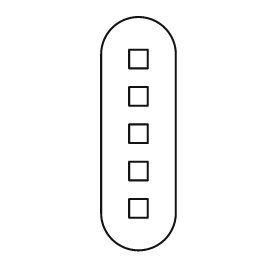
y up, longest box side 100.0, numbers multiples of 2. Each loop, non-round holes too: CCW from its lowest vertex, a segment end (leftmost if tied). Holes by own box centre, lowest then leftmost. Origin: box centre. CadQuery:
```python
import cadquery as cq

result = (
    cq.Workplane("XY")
    .moveTo(-16.0, -34.0)
    .threePointArc((0.0, -50.0), (16.0, -34.0))
    .lineTo(16.0, 34.0)
    .threePointArc((0.0, 50.0), (-16.0, 34.0))
    .close()
    .moveTo(-4.0, -36.0)
    .lineTo(4.0, -36.0)
    .lineTo(4.0, -28.0)
    .lineTo(-4.0, -28.0)
    .close()
    .moveTo(-4.0, -20.0)
    .lineTo(4.0, -20.0)
    .lineTo(4.0, -12.0)
    .lineTo(-4.0, -12.0)
    .close()
    .moveTo(-4.0, -4.0)
    .lineTo(4.0, -4.0)
    .lineTo(4.0, 4.0)
    .lineTo(-4.0, 4.0)
    .close()
    .moveTo(-4.0, 12.0)
    .lineTo(4.0, 12.0)
    .lineTo(4.0, 20.0)
    .lineTo(-4.0, 20.0)
    .close()
    .moveTo(-4.0, 28.0)
    .lineTo(4.0, 28.0)
    .lineTo(4.0, 36.0)
    .lineTo(-4.0, 36.0)
    .close()
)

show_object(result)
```